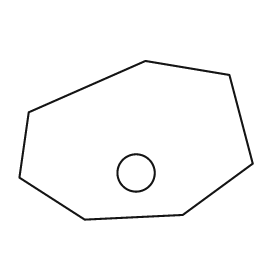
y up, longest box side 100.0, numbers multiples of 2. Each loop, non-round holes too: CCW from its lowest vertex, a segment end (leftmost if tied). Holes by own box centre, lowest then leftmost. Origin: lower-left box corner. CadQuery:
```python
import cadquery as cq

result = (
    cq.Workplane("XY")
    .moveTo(28.0, 0.0)
    .lineTo(70.0, 2.0)
    .lineTo(100.0, 24.0)
    .lineTo(90.0, 62.0)
    .lineTo(54.0, 68.0)
    .lineTo(4.0, 46.0)
    .lineTo(0.0, 18.0)
    .close()
    .moveTo(50.0, 20.0)
    .circle(8.0)
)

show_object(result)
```